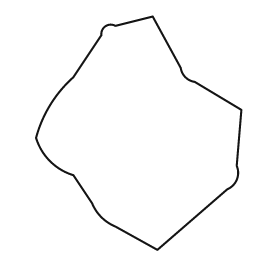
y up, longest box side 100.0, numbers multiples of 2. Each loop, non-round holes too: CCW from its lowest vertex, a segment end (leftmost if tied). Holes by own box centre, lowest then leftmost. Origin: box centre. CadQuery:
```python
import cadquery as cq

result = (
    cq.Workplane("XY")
    .moveTo(8.0, -50.0)
    .lineTo(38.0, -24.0)
    .threePointArc((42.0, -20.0), (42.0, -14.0))
    .lineTo(44.0, 10.0)
    .lineTo(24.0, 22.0)
    .threePointArc((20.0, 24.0), (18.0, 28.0))
    .lineTo(6.0, 50.0)
    .lineTo(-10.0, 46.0)
    .threePointArc((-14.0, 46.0), (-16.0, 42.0))
    .lineTo(-28.0, 24.0)
    .threePointArc((-38.0, 12.0), (-44.0, -2.0))
    .threePointArc((-38.0, -12.0), (-28.0, -18.0))
    .lineTo(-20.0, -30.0)
    .threePointArc((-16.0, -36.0), (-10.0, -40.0))
    .close()
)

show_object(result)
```